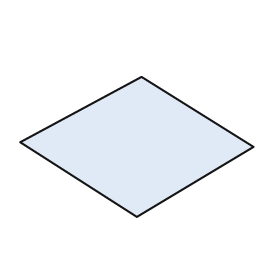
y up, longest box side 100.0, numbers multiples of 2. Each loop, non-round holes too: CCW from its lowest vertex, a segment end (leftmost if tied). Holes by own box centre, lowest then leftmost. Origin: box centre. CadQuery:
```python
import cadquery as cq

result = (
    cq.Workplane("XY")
    .moveTo(0.0, -30.0)
    .lineTo(50.0, 0.0)
    .lineTo(2.0, 30.0)
    .lineTo(-50.0, 2.0)
    .close()
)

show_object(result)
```